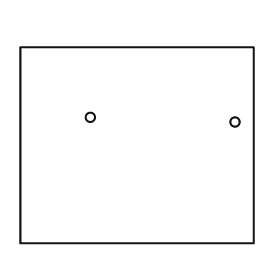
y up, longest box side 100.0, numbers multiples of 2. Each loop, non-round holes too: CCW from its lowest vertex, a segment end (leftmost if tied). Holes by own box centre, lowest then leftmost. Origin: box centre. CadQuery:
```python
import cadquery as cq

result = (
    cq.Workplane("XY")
    .moveTo(-50.0, -42.0)
    .lineTo(50.0, -42.0)
    .lineTo(50.0, 42.0)
    .lineTo(-50.0, 42.0)
    .close()
    .moveTo(42.0, 10.0)
    .circle(2.0)
    .moveTo(-20.0, 12.0)
    .circle(2.0)
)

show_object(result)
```